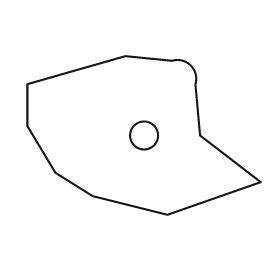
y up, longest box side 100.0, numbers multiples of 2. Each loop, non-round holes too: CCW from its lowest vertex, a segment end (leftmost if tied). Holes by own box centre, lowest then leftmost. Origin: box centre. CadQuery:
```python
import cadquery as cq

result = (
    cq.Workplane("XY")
    .moveTo(10.0, -34.0)
    .lineTo(50.0, -20.0)
    .lineTo(24.0, 0.0)
    .lineTo(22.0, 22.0)
    .threePointArc((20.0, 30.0), (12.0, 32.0))
    .lineTo(-8.0, 34.0)
    .lineTo(-50.0, 22.0)
    .lineTo(-50.0, 4.0)
    .lineTo(-38.0, -16.0)
    .lineTo(-22.0, -26.0)
    .close()
    .moveTo(0.0, 0.0)
    .circle(6.0)
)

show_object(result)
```